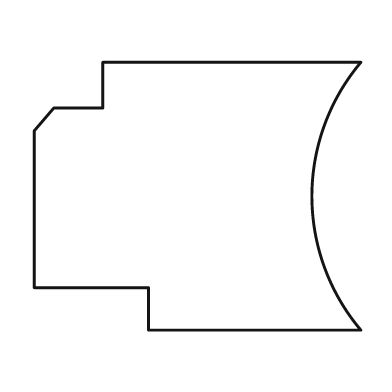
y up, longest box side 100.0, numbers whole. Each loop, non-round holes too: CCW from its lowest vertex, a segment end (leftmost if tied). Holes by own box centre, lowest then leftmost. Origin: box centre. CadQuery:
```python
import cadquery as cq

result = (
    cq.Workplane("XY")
    .moveTo(-15.0, -41.0)
    .lineTo(50.0, -41.0)
    .threePointArc((35.0, 0.0), (50.0, 41.0))
    .lineTo(-29.0, 41.0)
    .lineTo(-29.0, 27.0)
    .lineTo(-44.0, 27.0)
    .lineTo(-50.0, 20.0)
    .lineTo(-50.0, -28.0)
    .lineTo(-15.0, -28.0)
    .close()
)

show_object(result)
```